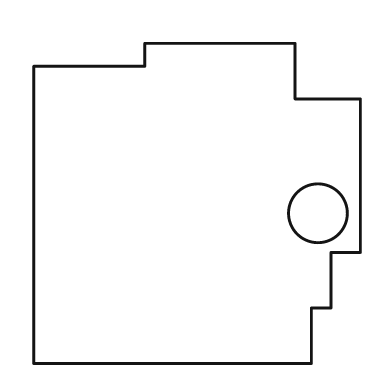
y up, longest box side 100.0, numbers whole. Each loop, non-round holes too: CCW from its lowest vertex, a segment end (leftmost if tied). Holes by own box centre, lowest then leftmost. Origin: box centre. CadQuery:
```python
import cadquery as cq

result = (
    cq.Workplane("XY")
    .moveTo(-50.0, -49.0)
    .lineTo(35.0, -49.0)
    .lineTo(35.0, -32.0)
    .lineTo(41.0, -32.0)
    .lineTo(41.0, -15.0)
    .lineTo(50.0, -15.0)
    .lineTo(50.0, 32.0)
    .lineTo(30.0, 32.0)
    .lineTo(30.0, 49.0)
    .lineTo(-16.0, 49.0)
    .lineTo(-16.0, 42.0)
    .lineTo(-50.0, 42.0)
    .close()
    .moveTo(37.0, -3.0)
    .circle(9.0)
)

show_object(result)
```